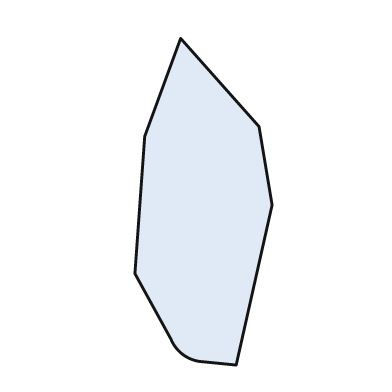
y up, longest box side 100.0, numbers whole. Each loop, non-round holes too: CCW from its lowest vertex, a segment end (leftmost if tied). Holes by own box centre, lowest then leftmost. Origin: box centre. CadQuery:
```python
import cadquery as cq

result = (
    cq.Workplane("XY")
    .moveTo(10.0, -50.0)
    .lineTo(21.0, -1.0)
    .lineTo(17.0, 23.0)
    .lineTo(-7.0, 50.0)
    .lineTo(-18.0, 20.0)
    .lineTo(-21.0, -22.0)
    .lineTo(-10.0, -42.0)
    .threePointArc((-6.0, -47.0), (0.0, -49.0))
    .close()
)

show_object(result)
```